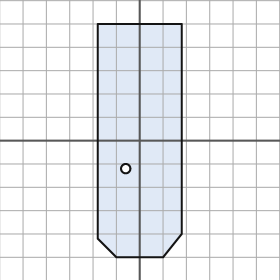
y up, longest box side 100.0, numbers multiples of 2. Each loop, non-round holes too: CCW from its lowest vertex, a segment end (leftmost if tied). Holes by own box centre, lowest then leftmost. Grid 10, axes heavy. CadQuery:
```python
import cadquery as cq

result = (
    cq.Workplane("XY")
    .moveTo(-10.0, -50.0)
    .lineTo(10.0, -50.0)
    .lineTo(18.0, -40.0)
    .lineTo(18.0, 50.0)
    .lineTo(-18.0, 50.0)
    .lineTo(-18.0, -42.0)
    .close()
    .moveTo(-6.0, -12.0)
    .circle(2.0)
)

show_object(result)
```